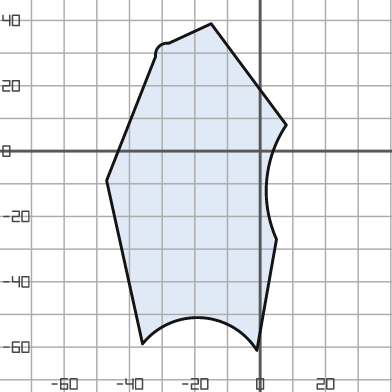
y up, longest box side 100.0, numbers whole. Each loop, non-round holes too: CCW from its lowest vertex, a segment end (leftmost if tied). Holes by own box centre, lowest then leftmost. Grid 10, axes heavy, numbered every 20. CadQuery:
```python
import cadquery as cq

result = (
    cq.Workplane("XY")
    .moveTo(-1.0, -61.0)
    .lineTo(5.0, -27.0)
    .threePointArc((2.0, -9.0), (8.0, 8.0))
    .lineTo(-15.0, 39.0)
    .lineTo(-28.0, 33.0)
    .threePointArc((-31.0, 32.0), (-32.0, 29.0))
    .lineTo(-47.0, -9.0)
    .lineTo(-36.0, -59.0)
    .threePointArc((-18.0, -51.0), (-1.0, -61.0))
    .close()
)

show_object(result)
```